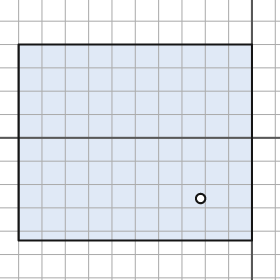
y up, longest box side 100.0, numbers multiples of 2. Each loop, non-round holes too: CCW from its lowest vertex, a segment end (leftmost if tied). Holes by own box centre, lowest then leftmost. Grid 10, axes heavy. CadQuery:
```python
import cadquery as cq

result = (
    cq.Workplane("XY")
    .moveTo(-100.0, -44.0)
    .lineTo(0.0, -44.0)
    .lineTo(0.0, 40.0)
    .lineTo(-100.0, 40.0)
    .close()
    .moveTo(-22.0, -26.0)
    .circle(2.0)
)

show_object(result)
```